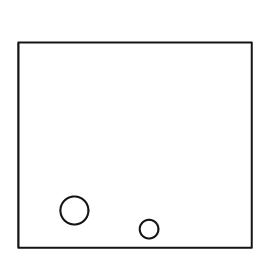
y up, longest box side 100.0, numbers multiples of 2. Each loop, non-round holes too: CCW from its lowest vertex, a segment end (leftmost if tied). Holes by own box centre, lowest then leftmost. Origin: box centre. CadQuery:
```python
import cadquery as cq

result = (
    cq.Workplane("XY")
    .moveTo(-50.0, -44.0)
    .lineTo(50.0, -44.0)
    .lineTo(50.0, 44.0)
    .lineTo(-50.0, 44.0)
    .close()
    .moveTo(6.0, -36.0)
    .circle(4.0)
    .moveTo(-26.0, -28.0)
    .circle(6.0)
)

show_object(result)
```